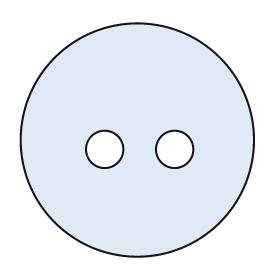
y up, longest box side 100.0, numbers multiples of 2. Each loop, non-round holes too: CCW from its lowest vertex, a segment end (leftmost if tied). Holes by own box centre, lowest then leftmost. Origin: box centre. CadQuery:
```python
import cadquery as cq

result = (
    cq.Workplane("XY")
    .moveTo(0.0, 0.0)
    .circle(50.0)
    .moveTo(-14.0, -4.0)
    .circle(8.0)
    .moveTo(16.0, -4.0)
    .circle(8.0)
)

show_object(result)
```